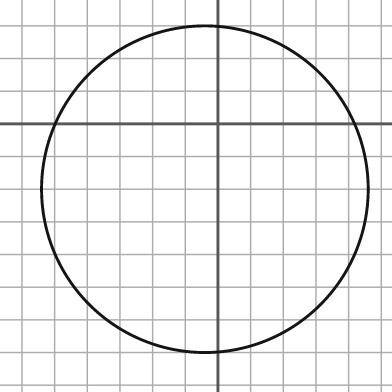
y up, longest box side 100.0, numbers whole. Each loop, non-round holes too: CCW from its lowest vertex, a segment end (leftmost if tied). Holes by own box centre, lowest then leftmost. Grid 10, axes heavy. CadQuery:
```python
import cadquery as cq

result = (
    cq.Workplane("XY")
    .moveTo(-4.0, -20.0)
    .circle(50.0)
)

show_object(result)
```